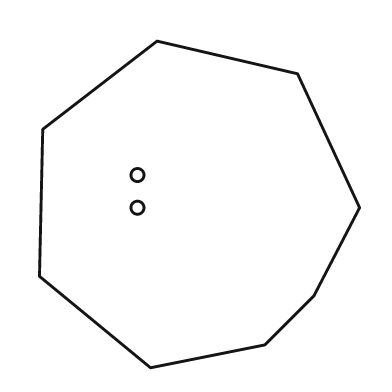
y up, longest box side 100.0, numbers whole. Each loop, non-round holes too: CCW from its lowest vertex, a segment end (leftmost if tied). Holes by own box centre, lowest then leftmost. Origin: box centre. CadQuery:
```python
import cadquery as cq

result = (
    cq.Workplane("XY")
    .moveTo(-15.0, -50.0)
    .lineTo(20.0, -43.0)
    .lineTo(35.0, -28.0)
    .lineTo(49.0, -1.0)
    .lineTo(30.0, 40.0)
    .lineTo(-13.0, 50.0)
    .lineTo(-48.0, 23.0)
    .lineTo(-49.0, -22.0)
    .close()
    .moveTo(-19.0, -1.0)
    .circle(2.0)
    .moveTo(-19.0, 9.0)
    .circle(2.0)
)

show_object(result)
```